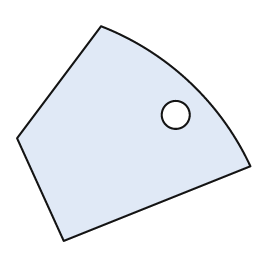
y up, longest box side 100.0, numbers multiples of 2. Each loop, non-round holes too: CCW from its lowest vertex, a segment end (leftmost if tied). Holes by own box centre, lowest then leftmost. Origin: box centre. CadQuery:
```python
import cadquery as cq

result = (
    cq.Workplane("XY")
    .moveTo(-30.0, -46.0)
    .lineTo(50.0, -14.0)
    .threePointArc((24.0, 22.0), (-14.0, 46.0))
    .lineTo(-50.0, -2.0)
    .close()
    .moveTo(18.0, 8.0)
    .circle(6.0)
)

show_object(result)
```